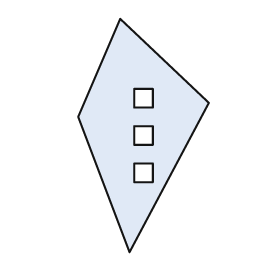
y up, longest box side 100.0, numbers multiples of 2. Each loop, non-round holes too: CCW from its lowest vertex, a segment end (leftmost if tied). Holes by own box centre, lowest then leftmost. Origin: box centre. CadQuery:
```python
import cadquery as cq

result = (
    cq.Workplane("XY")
    .moveTo(-6.0, -50.0)
    .lineTo(28.0, 14.0)
    .lineTo(-10.0, 50.0)
    .lineTo(-28.0, 8.0)
    .close()
    .moveTo(-4.0, -20.0)
    .lineTo(4.0, -20.0)
    .lineTo(4.0, -12.0)
    .lineTo(-4.0, -12.0)
    .close()
    .moveTo(-4.0, -4.0)
    .lineTo(4.0, -4.0)
    .lineTo(4.0, 4.0)
    .lineTo(-4.0, 4.0)
    .close()
    .moveTo(-4.0, 12.0)
    .lineTo(4.0, 12.0)
    .lineTo(4.0, 20.0)
    .lineTo(-4.0, 20.0)
    .close()
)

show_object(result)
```